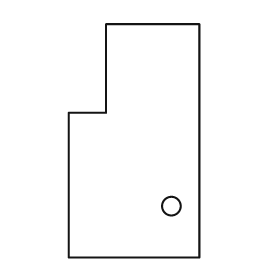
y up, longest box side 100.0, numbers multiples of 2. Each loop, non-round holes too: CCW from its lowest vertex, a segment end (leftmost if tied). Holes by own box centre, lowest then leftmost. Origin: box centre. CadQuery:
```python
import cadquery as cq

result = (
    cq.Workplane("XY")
    .moveTo(-28.0, -50.0)
    .lineTo(28.0, -50.0)
    .lineTo(28.0, 50.0)
    .lineTo(-12.0, 50.0)
    .lineTo(-12.0, 12.0)
    .lineTo(-28.0, 12.0)
    .close()
    .moveTo(16.0, -28.0)
    .circle(4.0)
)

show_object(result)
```